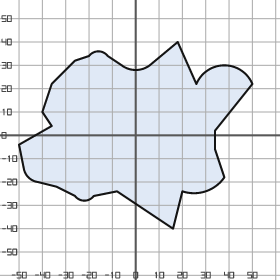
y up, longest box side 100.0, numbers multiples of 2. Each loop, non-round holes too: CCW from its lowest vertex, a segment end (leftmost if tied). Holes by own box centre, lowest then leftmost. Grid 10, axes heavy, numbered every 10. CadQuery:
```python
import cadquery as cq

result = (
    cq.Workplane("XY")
    .moveTo(16.0, -40.0)
    .lineTo(20.0, -24.0)
    .threePointArc((30.0, -24.0), (38.0, -18.0))
    .lineTo(34.0, -6.0)
    .lineTo(34.0, 2.0)
    .lineTo(50.0, 22.0)
    .threePointArc((38.0, 30.0), (26.0, 22.0))
    .lineTo(18.0, 40.0)
    .lineTo(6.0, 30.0)
    .threePointArc((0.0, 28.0), (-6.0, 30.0))
    .lineTo(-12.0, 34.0)
    .threePointArc((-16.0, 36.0), (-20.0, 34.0))
    .lineTo(-26.0, 32.0)
    .lineTo(-36.0, 22.0)
    .lineTo(-40.0, 10.0)
    .lineTo(-36.0, 4.0)
    .lineTo(-50.0, -4.0)
    .lineTo(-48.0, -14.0)
    .threePointArc((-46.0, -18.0), (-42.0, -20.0))
    .lineTo(-34.0, -22.0)
    .lineTo(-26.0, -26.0)
    .threePointArc((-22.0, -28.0), (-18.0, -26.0))
    .lineTo(-8.0, -24.0)
    .close()
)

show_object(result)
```